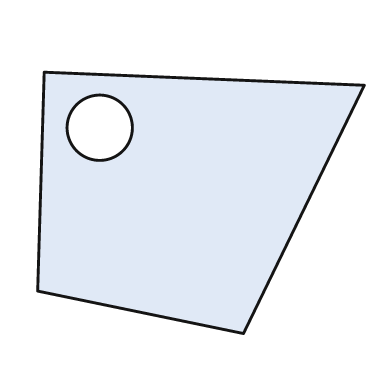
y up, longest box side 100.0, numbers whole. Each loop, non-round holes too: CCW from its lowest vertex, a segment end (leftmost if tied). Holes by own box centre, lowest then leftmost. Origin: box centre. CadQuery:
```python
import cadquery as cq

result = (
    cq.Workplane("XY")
    .moveTo(13.0, -40.0)
    .lineTo(50.0, 36.0)
    .lineTo(-48.0, 40.0)
    .lineTo(-50.0, -27.0)
    .close()
    .moveTo(-31.0, 23.0)
    .circle(10.0)
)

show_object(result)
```